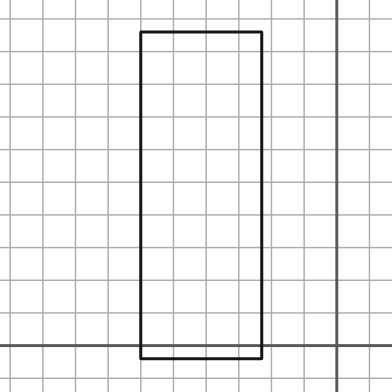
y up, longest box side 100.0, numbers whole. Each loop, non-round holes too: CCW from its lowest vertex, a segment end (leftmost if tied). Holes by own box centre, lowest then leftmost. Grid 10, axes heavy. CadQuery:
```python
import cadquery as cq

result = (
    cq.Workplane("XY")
    .moveTo(-60.0, -4.0)
    .lineTo(-23.0, -4.0)
    .lineTo(-23.0, 96.0)
    .lineTo(-60.0, 96.0)
    .close()
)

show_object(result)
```